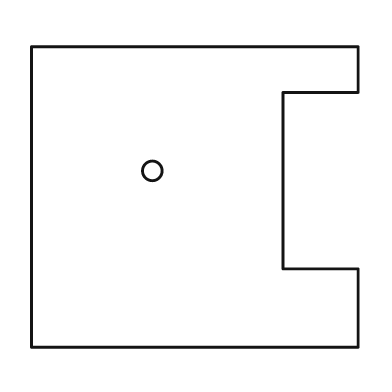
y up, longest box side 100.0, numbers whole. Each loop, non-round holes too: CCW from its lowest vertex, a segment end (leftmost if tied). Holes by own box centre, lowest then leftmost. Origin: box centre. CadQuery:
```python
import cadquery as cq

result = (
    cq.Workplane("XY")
    .moveTo(-50.0, -46.0)
    .lineTo(50.0, -46.0)
    .lineTo(50.0, -22.0)
    .lineTo(27.0, -22.0)
    .lineTo(27.0, 32.0)
    .lineTo(50.0, 32.0)
    .lineTo(50.0, 46.0)
    .lineTo(-50.0, 46.0)
    .close()
    .moveTo(-13.0, 8.0)
    .circle(3.0)
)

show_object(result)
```